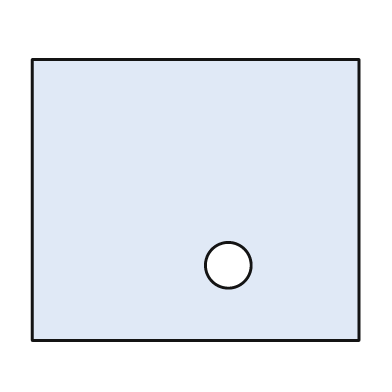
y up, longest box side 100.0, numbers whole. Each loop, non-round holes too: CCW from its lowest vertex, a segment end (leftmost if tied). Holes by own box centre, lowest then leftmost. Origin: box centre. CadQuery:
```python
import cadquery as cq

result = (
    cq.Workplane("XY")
    .moveTo(-50.0, -43.0)
    .lineTo(50.0, -43.0)
    .lineTo(50.0, 43.0)
    .lineTo(-50.0, 43.0)
    .close()
    .moveTo(10.0, -20.0)
    .circle(7.0)
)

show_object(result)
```